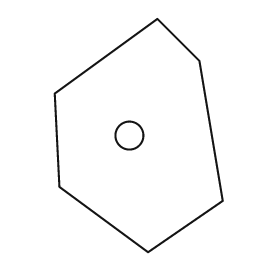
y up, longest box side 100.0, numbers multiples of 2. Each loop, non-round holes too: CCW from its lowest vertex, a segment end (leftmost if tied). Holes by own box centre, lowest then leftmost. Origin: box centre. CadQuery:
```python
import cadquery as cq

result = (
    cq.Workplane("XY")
    .moveTo(4.0, -50.0)
    .lineTo(36.0, -28.0)
    .lineTo(26.0, 32.0)
    .lineTo(8.0, 50.0)
    .lineTo(-36.0, 18.0)
    .lineTo(-34.0, -22.0)
    .close()
    .moveTo(-4.0, 0.0)
    .circle(6.0)
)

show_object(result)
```